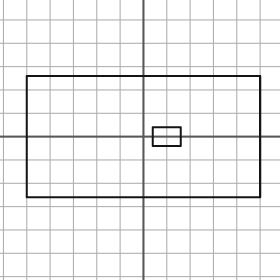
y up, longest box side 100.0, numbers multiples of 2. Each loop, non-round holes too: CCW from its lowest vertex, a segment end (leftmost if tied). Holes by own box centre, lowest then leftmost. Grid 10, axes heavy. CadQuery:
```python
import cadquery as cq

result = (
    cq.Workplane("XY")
    .moveTo(-50.0, -26.0)
    .lineTo(50.0, -26.0)
    .lineTo(50.0, 26.0)
    .lineTo(-50.0, 26.0)
    .close()
    .moveTo(4.0, -4.0)
    .lineTo(16.0, -4.0)
    .lineTo(16.0, 4.0)
    .lineTo(4.0, 4.0)
    .close()
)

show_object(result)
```